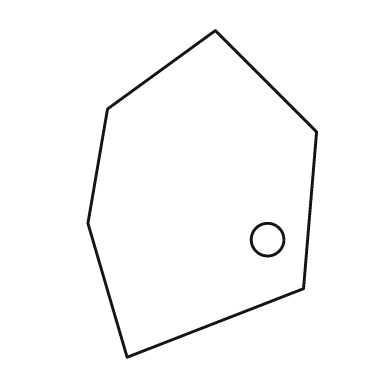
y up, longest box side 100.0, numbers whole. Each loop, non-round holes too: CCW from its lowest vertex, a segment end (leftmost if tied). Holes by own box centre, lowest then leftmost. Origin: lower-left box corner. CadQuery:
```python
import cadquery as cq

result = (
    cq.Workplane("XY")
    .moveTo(12.0, 0.0)
    .lineTo(66.0, 21.0)
    .lineTo(70.0, 69.0)
    .lineTo(39.0, 100.0)
    .lineTo(6.0, 76.0)
    .lineTo(0.0, 41.0)
    .close()
    .moveTo(55.0, 36.0)
    .circle(5.0)
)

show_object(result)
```